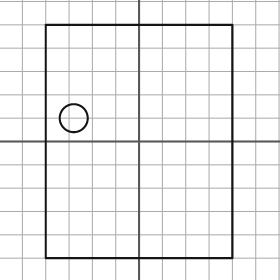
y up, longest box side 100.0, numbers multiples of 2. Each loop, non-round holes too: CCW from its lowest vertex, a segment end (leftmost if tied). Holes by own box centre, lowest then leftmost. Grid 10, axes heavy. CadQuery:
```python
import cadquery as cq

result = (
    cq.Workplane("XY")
    .moveTo(-40.0, -50.0)
    .lineTo(40.0, -50.0)
    .lineTo(40.0, 50.0)
    .lineTo(-40.0, 50.0)
    .close()
    .moveTo(-28.0, 10.0)
    .circle(6.0)
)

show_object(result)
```